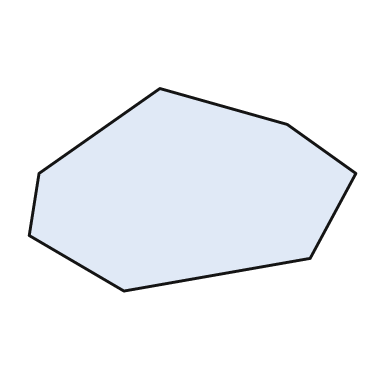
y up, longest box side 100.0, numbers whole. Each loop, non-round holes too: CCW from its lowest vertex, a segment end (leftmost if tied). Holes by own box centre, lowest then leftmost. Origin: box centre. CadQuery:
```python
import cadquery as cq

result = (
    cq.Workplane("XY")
    .moveTo(-21.0, -31.0)
    .lineTo(36.0, -21.0)
    .lineTo(50.0, 5.0)
    .lineTo(29.0, 20.0)
    .lineTo(-10.0, 31.0)
    .lineTo(-47.0, 5.0)
    .lineTo(-50.0, -14.0)
    .close()
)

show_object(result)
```